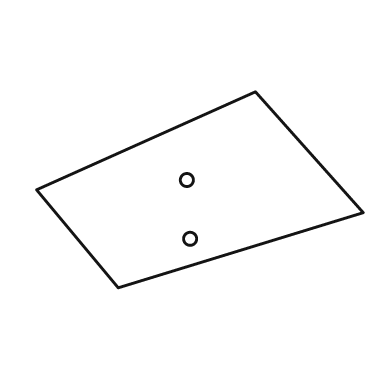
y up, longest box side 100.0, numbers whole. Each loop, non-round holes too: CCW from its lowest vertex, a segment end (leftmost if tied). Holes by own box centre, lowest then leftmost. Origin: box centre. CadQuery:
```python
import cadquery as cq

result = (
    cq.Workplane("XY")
    .moveTo(-25.0, -30.0)
    .lineTo(50.0, -7.0)
    .lineTo(17.0, 30.0)
    .lineTo(-50.0, 0.0)
    .close()
    .moveTo(-3.0, -15.0)
    .circle(2.0)
    .moveTo(-4.0, 3.0)
    .circle(2.0)
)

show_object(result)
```